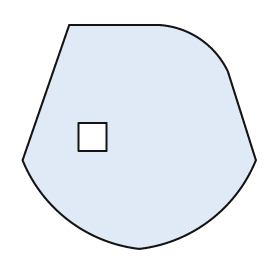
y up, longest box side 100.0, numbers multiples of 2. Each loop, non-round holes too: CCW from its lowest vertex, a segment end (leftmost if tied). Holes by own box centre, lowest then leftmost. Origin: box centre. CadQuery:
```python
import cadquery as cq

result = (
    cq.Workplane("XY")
    .moveTo(0.0, -48.0)
    .threePointArc((30.0, -36.0), (50.0, -10.0))
    .lineTo(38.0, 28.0)
    .threePointArc((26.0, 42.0), (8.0, 48.0))
    .lineTo(-30.0, 48.0)
    .lineTo(-50.0, -10.0)
    .threePointArc((-30.0, -36.0), (0.0, -48.0))
    .close()
    .moveTo(-26.0, -6.0)
    .lineTo(-14.0, -6.0)
    .lineTo(-14.0, 6.0)
    .lineTo(-26.0, 6.0)
    .close()
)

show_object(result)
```